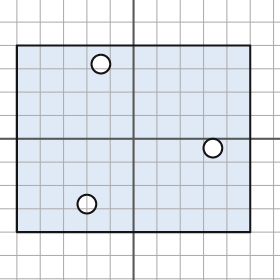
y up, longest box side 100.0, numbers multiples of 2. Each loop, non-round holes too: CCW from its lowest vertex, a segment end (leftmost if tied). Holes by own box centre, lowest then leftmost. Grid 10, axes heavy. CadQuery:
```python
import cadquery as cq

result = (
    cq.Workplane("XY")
    .moveTo(-50.0, -40.0)
    .lineTo(50.0, -40.0)
    .lineTo(50.0, 40.0)
    .lineTo(-50.0, 40.0)
    .close()
    .moveTo(-20.0, -28.0)
    .circle(4.0)
    .moveTo(34.0, -4.0)
    .circle(4.0)
    .moveTo(-14.0, 32.0)
    .circle(4.0)
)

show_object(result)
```